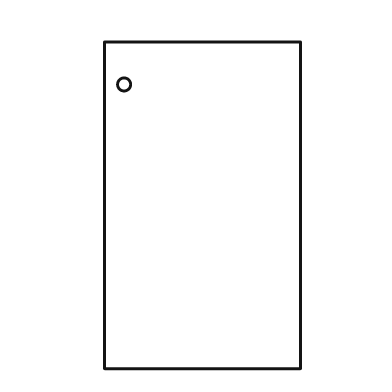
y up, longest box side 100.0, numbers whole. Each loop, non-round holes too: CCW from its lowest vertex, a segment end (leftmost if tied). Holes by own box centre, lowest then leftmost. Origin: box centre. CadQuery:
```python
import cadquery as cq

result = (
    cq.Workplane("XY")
    .moveTo(-30.0, -50.0)
    .lineTo(30.0, -50.0)
    .lineTo(30.0, 50.0)
    .lineTo(-30.0, 50.0)
    .close()
    .moveTo(-24.0, 37.0)
    .circle(2.0)
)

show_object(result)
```